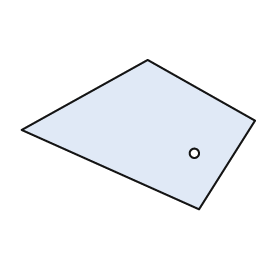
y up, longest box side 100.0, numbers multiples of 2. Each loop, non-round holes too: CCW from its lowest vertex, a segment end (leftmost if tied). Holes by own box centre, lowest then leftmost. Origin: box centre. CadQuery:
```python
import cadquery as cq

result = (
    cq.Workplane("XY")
    .moveTo(26.0, -32.0)
    .lineTo(50.0, 6.0)
    .lineTo(4.0, 32.0)
    .lineTo(-50.0, 2.0)
    .close()
    .moveTo(24.0, -8.0)
    .circle(2.0)
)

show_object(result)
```